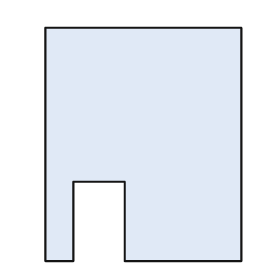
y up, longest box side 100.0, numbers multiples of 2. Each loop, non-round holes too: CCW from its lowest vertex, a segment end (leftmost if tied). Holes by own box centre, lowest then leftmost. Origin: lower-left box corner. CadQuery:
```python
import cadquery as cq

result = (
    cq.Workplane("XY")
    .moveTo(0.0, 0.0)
    .lineTo(12.0, 0.0)
    .lineTo(12.0, 34.0)
    .lineTo(34.0, 34.0)
    .lineTo(34.0, 0.0)
    .lineTo(84.0, 0.0)
    .lineTo(84.0, 100.0)
    .lineTo(0.0, 100.0)
    .close()
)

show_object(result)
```